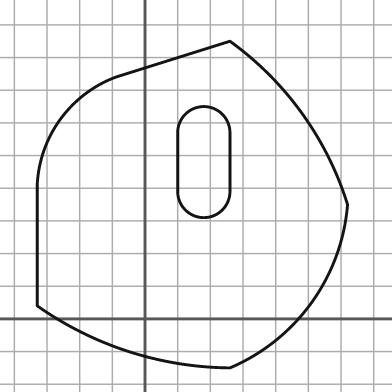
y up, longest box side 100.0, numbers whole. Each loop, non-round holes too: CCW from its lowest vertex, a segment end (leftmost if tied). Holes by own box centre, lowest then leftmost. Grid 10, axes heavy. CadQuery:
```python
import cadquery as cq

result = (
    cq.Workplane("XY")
    .moveTo(26.0, -15.0)
    .threePointArc((51.0, 5.0), (62.0, 35.0))
    .threePointArc((48.0, 63.0), (26.0, 85.0))
    .lineTo(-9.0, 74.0)
    .threePointArc((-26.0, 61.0), (-33.0, 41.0))
    .lineTo(-33.0, 4.0)
    .threePointArc((-5.0, -10.0), (26.0, -15.0))
    .close()
    .moveTo(10.0, 39.0)
    .threePointArc((18.0, 31.0), (26.0, 39.0))
    .lineTo(26.0, 57.0)
    .threePointArc((18.0, 65.0), (10.0, 57.0))
    .close()
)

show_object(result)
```